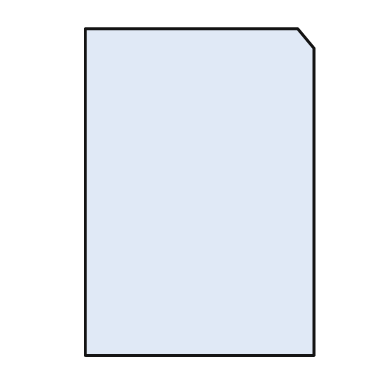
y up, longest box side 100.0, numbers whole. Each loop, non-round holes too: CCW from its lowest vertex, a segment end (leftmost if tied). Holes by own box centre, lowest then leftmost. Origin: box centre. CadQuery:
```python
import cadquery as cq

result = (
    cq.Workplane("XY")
    .moveTo(-35.0, -50.0)
    .lineTo(35.0, -50.0)
    .lineTo(35.0, 44.0)
    .lineTo(30.0, 50.0)
    .lineTo(-35.0, 50.0)
    .close()
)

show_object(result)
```